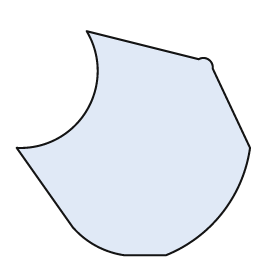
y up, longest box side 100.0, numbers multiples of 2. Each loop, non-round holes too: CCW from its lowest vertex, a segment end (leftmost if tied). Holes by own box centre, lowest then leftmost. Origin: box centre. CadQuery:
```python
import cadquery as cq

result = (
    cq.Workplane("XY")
    .moveTo(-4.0, -48.0)
    .lineTo(14.0, -48.0)
    .threePointArc((38.0, -30.0), (50.0, -2.0))
    .lineTo(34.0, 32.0)
    .threePointArc((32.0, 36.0), (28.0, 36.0))
    .lineTo(-20.0, 48.0)
    .threePointArc((-20.0, 14.0), (-50.0, -2.0))
    .lineTo(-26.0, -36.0)
    .threePointArc((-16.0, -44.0), (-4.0, -48.0))
    .close()
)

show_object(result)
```